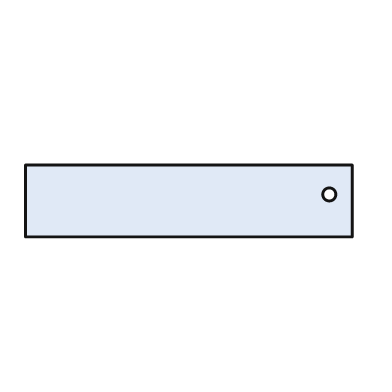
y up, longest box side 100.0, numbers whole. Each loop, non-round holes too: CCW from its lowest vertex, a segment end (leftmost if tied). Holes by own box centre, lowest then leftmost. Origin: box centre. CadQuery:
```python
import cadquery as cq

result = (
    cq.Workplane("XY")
    .moveTo(-50.0, -11.0)
    .lineTo(50.0, -11.0)
    .lineTo(50.0, 11.0)
    .lineTo(-50.0, 11.0)
    .close()
    .moveTo(43.0, 2.0)
    .circle(2.0)
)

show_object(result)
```